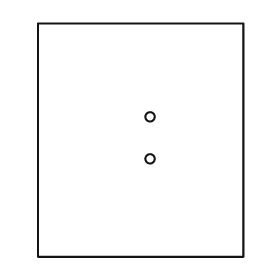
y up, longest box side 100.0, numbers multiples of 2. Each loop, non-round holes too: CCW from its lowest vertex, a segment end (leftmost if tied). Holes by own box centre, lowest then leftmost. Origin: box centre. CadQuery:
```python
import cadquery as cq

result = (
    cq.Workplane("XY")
    .moveTo(-44.0, -50.0)
    .lineTo(44.0, -50.0)
    .lineTo(44.0, 50.0)
    .lineTo(-44.0, 50.0)
    .close()
    .moveTo(4.0, -8.0)
    .circle(2.0)
    .moveTo(4.0, 10.0)
    .circle(2.0)
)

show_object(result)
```